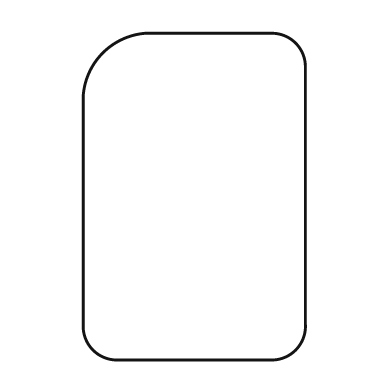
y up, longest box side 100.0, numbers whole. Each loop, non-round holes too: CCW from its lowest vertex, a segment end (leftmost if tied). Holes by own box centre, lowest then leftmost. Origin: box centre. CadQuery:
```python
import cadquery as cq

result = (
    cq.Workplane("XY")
    .moveTo(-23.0, -50.0)
    .lineTo(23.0, -50.0)
    .threePointArc((31.0, -47.0), (34.0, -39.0))
    .lineTo(34.0, 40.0)
    .threePointArc((31.0, 47.0), (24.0, 50.0))
    .lineTo(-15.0, 50.0)
    .threePointArc((-28.0, 44.0), (-34.0, 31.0))
    .lineTo(-34.0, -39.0)
    .threePointArc((-31.0, -47.0), (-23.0, -50.0))
    .close()
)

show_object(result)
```